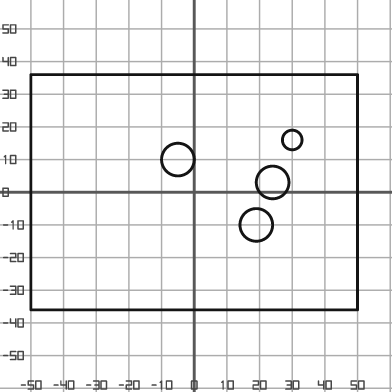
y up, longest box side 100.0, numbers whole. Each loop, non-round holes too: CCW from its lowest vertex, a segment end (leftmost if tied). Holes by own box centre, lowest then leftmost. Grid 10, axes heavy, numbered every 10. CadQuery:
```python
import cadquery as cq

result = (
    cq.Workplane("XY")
    .moveTo(-50.0, -36.0)
    .lineTo(50.0, -36.0)
    .lineTo(50.0, 36.0)
    .lineTo(-50.0, 36.0)
    .close()
    .moveTo(19.0, -10.0)
    .circle(5.0)
    .moveTo(24.0, 3.0)
    .circle(5.0)
    .moveTo(-5.0, 10.0)
    .circle(5.0)
    .moveTo(30.0, 16.0)
    .circle(3.0)
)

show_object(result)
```